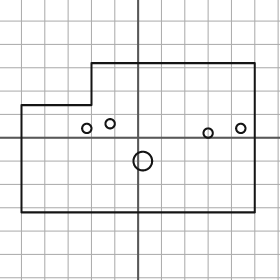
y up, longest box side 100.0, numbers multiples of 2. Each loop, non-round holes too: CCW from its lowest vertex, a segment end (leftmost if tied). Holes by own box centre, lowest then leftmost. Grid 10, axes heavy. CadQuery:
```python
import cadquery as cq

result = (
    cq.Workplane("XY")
    .moveTo(-50.0, -32.0)
    .lineTo(50.0, -32.0)
    .lineTo(50.0, 32.0)
    .lineTo(-20.0, 32.0)
    .lineTo(-20.0, 14.0)
    .lineTo(-50.0, 14.0)
    .close()
    .moveTo(2.0, -10.0)
    .circle(4.0)
    .moveTo(30.0, 2.0)
    .circle(2.0)
    .moveTo(-22.0, 4.0)
    .circle(2.0)
    .moveTo(44.0, 4.0)
    .circle(2.0)
    .moveTo(-12.0, 6.0)
    .circle(2.0)
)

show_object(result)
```